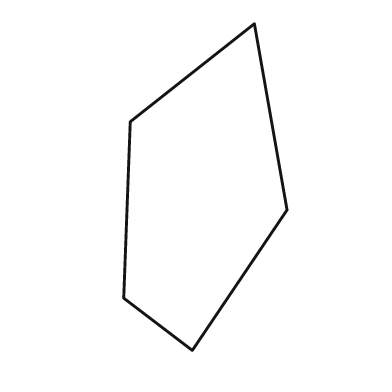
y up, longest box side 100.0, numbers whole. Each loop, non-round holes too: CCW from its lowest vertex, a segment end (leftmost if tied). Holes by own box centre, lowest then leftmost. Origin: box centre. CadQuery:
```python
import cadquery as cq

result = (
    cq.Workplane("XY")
    .moveTo(-4.0, -50.0)
    .lineTo(25.0, -7.0)
    .lineTo(15.0, 50.0)
    .lineTo(-23.0, 20.0)
    .lineTo(-25.0, -34.0)
    .close()
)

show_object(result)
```